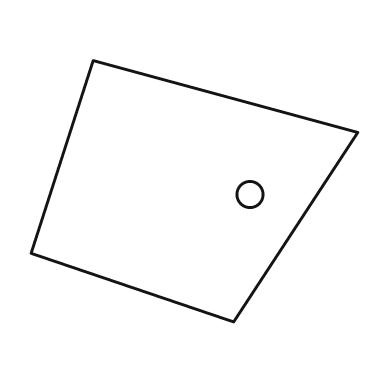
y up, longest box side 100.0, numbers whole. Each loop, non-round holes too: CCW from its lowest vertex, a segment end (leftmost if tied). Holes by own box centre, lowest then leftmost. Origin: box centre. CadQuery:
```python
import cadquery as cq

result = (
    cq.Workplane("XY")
    .moveTo(12.0, -40.0)
    .lineTo(50.0, 18.0)
    .lineTo(-31.0, 40.0)
    .lineTo(-50.0, -19.0)
    .close()
    .moveTo(17.0, -1.0)
    .circle(4.0)
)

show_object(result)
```